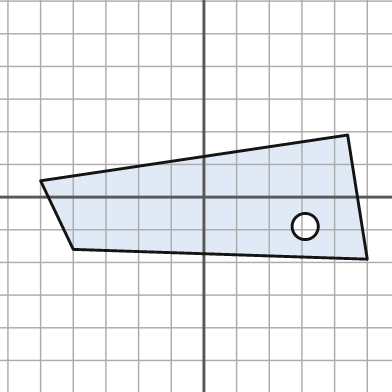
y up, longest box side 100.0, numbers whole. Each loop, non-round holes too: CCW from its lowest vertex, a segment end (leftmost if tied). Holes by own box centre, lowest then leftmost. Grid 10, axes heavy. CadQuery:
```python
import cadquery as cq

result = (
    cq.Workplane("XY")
    .moveTo(50.0, -19.0)
    .lineTo(44.0, 19.0)
    .lineTo(-50.0, 5.0)
    .lineTo(-40.0, -16.0)
    .close()
    .moveTo(31.0, -9.0)
    .circle(4.0)
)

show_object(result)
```